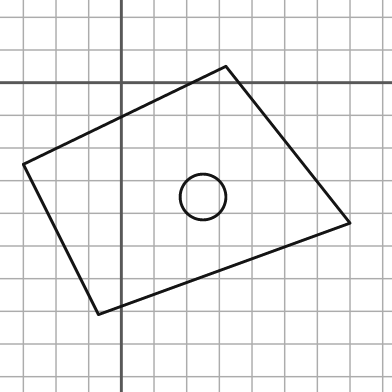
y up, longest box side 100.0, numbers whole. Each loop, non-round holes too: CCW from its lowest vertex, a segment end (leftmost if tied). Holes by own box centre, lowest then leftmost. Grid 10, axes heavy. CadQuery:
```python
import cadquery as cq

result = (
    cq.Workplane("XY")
    .moveTo(-7.0, -71.0)
    .lineTo(70.0, -43.0)
    .lineTo(32.0, 5.0)
    .lineTo(-30.0, -25.0)
    .close()
    .moveTo(25.0, -35.0)
    .circle(7.0)
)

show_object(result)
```